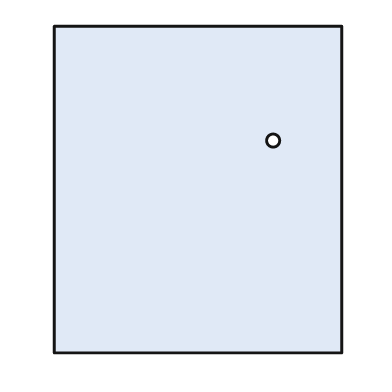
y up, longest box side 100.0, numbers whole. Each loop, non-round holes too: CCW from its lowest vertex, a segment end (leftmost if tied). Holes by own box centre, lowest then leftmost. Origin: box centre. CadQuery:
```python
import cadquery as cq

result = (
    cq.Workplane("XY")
    .moveTo(-44.0, -50.0)
    .lineTo(44.0, -50.0)
    .lineTo(44.0, 50.0)
    .lineTo(-44.0, 50.0)
    .close()
    .moveTo(23.0, 15.0)
    .circle(2.0)
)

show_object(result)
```